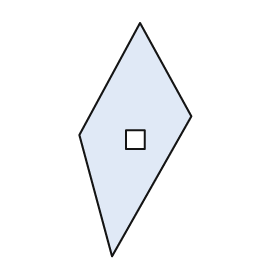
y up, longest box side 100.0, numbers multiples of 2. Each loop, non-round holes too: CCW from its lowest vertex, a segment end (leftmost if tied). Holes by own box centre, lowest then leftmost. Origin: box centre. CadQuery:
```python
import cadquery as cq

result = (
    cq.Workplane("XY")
    .moveTo(-10.0, -50.0)
    .lineTo(24.0, 10.0)
    .lineTo(2.0, 50.0)
    .lineTo(-24.0, 2.0)
    .close()
    .moveTo(-4.0, -4.0)
    .lineTo(4.0, -4.0)
    .lineTo(4.0, 4.0)
    .lineTo(-4.0, 4.0)
    .close()
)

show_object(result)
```